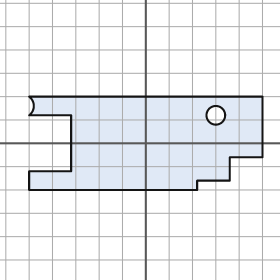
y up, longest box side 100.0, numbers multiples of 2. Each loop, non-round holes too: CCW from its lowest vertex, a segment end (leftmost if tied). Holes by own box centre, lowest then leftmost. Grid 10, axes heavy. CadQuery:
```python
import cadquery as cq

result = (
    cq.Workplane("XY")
    .moveTo(-50.0, -20.0)
    .lineTo(22.0, -20.0)
    .lineTo(22.0, -16.0)
    .lineTo(36.0, -16.0)
    .lineTo(36.0, -6.0)
    .lineTo(50.0, -6.0)
    .lineTo(50.0, 20.0)
    .lineTo(-50.0, 20.0)
    .threePointArc((-48.0, 16.0), (-50.0, 12.0))
    .lineTo(-32.0, 12.0)
    .lineTo(-32.0, -12.0)
    .lineTo(-50.0, -12.0)
    .close()
    .moveTo(30.0, 12.0)
    .circle(4.0)
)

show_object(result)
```